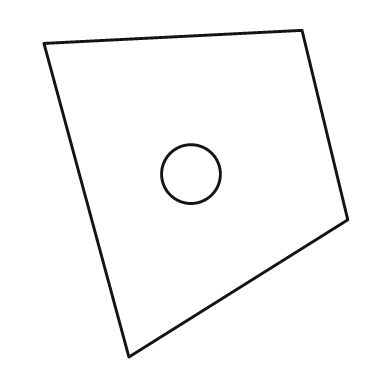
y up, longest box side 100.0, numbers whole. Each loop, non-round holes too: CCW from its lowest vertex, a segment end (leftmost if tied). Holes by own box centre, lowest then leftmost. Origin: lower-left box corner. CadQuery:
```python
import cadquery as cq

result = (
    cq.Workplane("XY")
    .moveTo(26.0, 0.0)
    .lineTo(93.0, 42.0)
    .lineTo(79.0, 100.0)
    .lineTo(0.0, 96.0)
    .close()
    .moveTo(45.0, 56.0)
    .circle(9.0)
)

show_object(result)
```